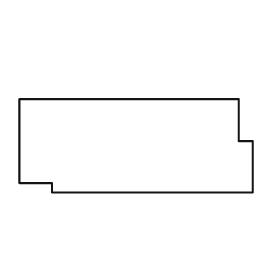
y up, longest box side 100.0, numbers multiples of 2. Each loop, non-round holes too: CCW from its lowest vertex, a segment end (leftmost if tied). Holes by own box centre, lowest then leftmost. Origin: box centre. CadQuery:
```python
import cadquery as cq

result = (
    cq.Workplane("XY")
    .moveTo(-36.0, -20.0)
    .lineTo(50.0, -20.0)
    .lineTo(50.0, 2.0)
    .lineTo(44.0, 2.0)
    .lineTo(44.0, 20.0)
    .lineTo(-50.0, 20.0)
    .lineTo(-50.0, -16.0)
    .lineTo(-36.0, -16.0)
    .close()
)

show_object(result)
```